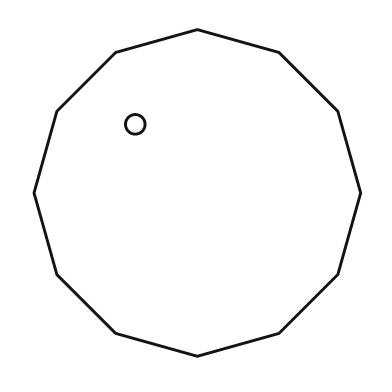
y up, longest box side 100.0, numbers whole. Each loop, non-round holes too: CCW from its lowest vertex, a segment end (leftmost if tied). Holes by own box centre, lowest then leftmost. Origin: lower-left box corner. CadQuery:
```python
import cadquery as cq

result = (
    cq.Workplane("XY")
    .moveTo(50.0, 0.0)
    .lineTo(75.0, 7.0)
    .lineTo(93.0, 25.0)
    .lineTo(100.0, 50.0)
    .lineTo(93.0, 75.0)
    .lineTo(75.0, 93.0)
    .lineTo(50.0, 100.0)
    .lineTo(25.0, 93.0)
    .lineTo(7.0, 75.0)
    .lineTo(0.0, 50.0)
    .lineTo(7.0, 25.0)
    .lineTo(25.0, 7.0)
    .close()
    .moveTo(31.0, 71.0)
    .circle(3.0)
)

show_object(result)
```